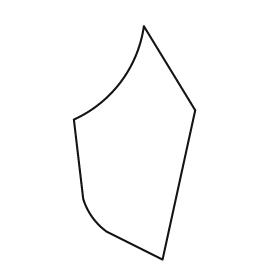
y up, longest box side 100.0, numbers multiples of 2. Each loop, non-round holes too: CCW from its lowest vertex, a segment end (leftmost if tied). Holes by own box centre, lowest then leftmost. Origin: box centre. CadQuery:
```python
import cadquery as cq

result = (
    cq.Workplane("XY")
    .moveTo(12.0, -50.0)
    .lineTo(26.0, 14.0)
    .lineTo(4.0, 50.0)
    .threePointArc((-6.0, 26.0), (-26.0, 10.0))
    .lineTo(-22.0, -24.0)
    .threePointArc((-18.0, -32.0), (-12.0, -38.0))
    .close()
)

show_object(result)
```